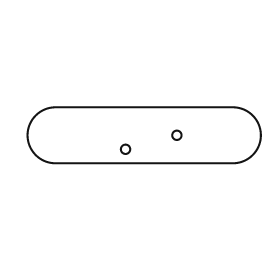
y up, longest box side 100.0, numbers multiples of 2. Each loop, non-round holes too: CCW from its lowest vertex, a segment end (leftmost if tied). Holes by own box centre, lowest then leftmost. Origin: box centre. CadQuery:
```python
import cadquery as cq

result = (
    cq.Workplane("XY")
    .moveTo(-38.0, -12.0)
    .lineTo(38.0, -12.0)
    .threePointArc((50.0, 0.0), (38.0, 12.0))
    .lineTo(-38.0, 12.0)
    .threePointArc((-50.0, 0.0), (-38.0, -12.0))
    .close()
    .moveTo(-8.0, -6.0)
    .circle(2.0)
    .moveTo(14.0, 0.0)
    .circle(2.0)
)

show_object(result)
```